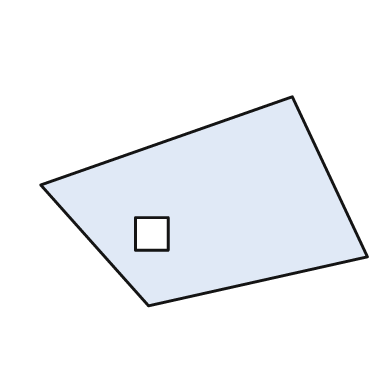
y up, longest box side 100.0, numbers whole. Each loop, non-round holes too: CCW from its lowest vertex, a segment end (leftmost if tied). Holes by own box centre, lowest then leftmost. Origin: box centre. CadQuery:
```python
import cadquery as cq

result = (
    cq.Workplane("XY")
    .moveTo(-17.0, -32.0)
    .lineTo(50.0, -17.0)
    .lineTo(27.0, 32.0)
    .lineTo(-50.0, 5.0)
    .close()
    .moveTo(-21.0, -15.0)
    .lineTo(-11.0, -15.0)
    .lineTo(-11.0, -5.0)
    .lineTo(-21.0, -5.0)
    .close()
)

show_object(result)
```